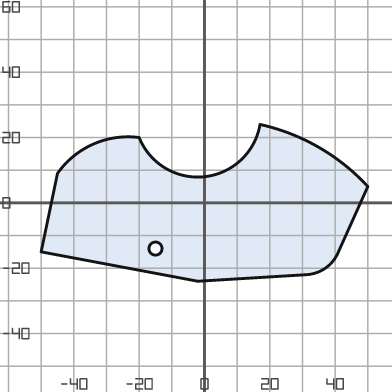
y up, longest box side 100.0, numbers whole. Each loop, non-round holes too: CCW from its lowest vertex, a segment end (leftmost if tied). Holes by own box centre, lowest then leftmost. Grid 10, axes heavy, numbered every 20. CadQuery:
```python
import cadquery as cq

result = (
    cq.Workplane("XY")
    .moveTo(-2.0, -24.0)
    .lineTo(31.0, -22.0)
    .threePointArc((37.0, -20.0), (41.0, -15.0))
    .lineTo(50.0, 5.0)
    .threePointArc((35.0, 17.0), (17.0, 24.0))
    .threePointArc((0.0, 8.0), (-20.0, 20.0))
    .threePointArc((-34.0, 18.0), (-45.0, 9.0))
    .lineTo(-50.0, -15.0)
    .close()
    .moveTo(-15.0, -14.0)
    .circle(2.0)
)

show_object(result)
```